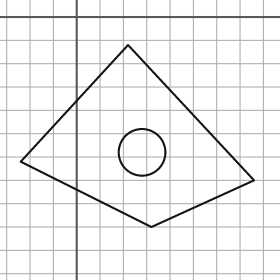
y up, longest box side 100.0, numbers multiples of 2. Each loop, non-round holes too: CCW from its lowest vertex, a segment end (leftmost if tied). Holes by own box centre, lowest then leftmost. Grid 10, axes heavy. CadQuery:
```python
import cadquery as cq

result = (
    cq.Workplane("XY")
    .moveTo(32.0, -90.0)
    .lineTo(76.0, -70.0)
    .lineTo(22.0, -12.0)
    .lineTo(-24.0, -62.0)
    .close()
    .moveTo(28.0, -58.0)
    .circle(10.0)
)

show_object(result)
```